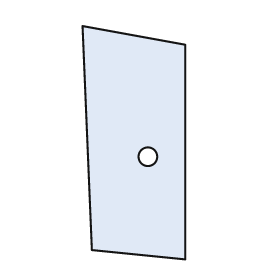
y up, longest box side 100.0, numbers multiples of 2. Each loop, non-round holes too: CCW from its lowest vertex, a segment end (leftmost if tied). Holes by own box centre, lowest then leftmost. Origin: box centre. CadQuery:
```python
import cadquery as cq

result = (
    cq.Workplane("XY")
    .moveTo(22.0, -50.0)
    .lineTo(22.0, 42.0)
    .lineTo(-22.0, 50.0)
    .lineTo(-18.0, -46.0)
    .close()
    .moveTo(6.0, -6.0)
    .circle(4.0)
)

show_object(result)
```